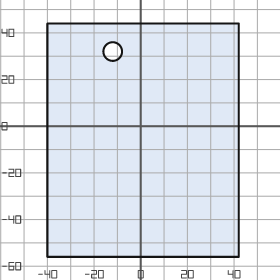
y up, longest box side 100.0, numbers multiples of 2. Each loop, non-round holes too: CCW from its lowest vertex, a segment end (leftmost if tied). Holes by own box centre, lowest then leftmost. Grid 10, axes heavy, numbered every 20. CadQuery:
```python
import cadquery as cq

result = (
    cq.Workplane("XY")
    .moveTo(-40.0, -56.0)
    .lineTo(42.0, -56.0)
    .lineTo(42.0, 44.0)
    .lineTo(-40.0, 44.0)
    .close()
    .moveTo(-12.0, 32.0)
    .circle(4.0)
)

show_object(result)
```